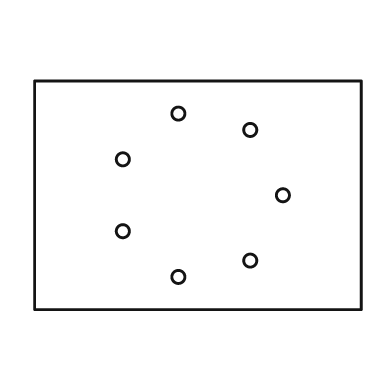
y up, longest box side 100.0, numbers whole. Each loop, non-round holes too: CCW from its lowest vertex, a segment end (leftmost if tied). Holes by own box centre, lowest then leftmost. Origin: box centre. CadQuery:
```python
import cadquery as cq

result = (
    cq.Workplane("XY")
    .moveTo(-50.0, -35.0)
    .lineTo(50.0, -35.0)
    .lineTo(50.0, 35.0)
    .lineTo(-50.0, 35.0)
    .close()
    .moveTo(-6.0, -25.0)
    .circle(2.0)
    .moveTo(16.0, -20.0)
    .circle(2.0)
    .moveTo(-23.0, -11.0)
    .circle(2.0)
    .moveTo(26.0, 0.0)
    .circle(2.0)
    .moveTo(-23.0, 11.0)
    .circle(2.0)
    .moveTo(16.0, 20.0)
    .circle(2.0)
    .moveTo(-6.0, 25.0)
    .circle(2.0)
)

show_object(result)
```